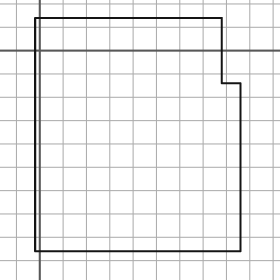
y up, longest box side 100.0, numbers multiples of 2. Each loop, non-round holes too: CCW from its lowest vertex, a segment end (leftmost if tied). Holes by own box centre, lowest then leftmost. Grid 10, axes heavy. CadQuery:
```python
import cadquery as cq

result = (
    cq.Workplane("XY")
    .moveTo(-2.0, -86.0)
    .lineTo(86.0, -86.0)
    .lineTo(86.0, -14.0)
    .lineTo(78.0, -14.0)
    .lineTo(78.0, 14.0)
    .lineTo(-2.0, 14.0)
    .close()
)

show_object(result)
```